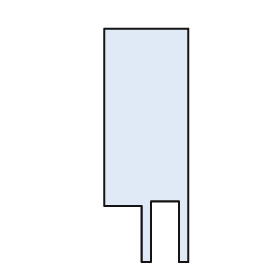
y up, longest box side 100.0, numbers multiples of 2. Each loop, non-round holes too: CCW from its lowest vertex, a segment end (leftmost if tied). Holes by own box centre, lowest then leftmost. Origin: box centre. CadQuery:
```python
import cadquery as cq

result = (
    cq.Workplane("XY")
    .moveTo(-2.0, -50.0)
    .lineTo(2.0, -50.0)
    .lineTo(2.0, -24.0)
    .lineTo(14.0, -24.0)
    .lineTo(14.0, -50.0)
    .lineTo(18.0, -50.0)
    .lineTo(18.0, 50.0)
    .lineTo(-18.0, 50.0)
    .lineTo(-18.0, -26.0)
    .lineTo(-2.0, -26.0)
    .close()
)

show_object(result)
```